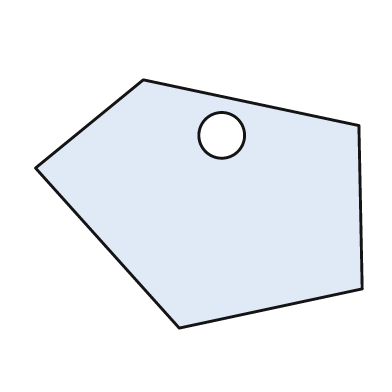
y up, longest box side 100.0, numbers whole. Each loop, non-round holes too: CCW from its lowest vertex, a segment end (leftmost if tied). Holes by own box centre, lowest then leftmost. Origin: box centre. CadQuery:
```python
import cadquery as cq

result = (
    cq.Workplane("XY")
    .moveTo(-6.0, -38.0)
    .lineTo(50.0, -26.0)
    .lineTo(49.0, 24.0)
    .lineTo(-17.0, 38.0)
    .lineTo(-50.0, 11.0)
    .close()
    .moveTo(7.0, 21.0)
    .circle(7.0)
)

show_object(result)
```